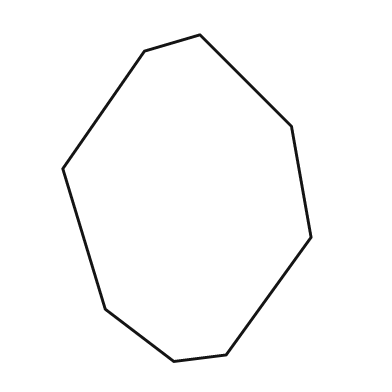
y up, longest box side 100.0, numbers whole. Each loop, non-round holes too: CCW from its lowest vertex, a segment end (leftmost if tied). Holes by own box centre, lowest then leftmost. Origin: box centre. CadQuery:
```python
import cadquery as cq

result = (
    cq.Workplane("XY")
    .moveTo(-4.0, -50.0)
    .lineTo(12.0, -48.0)
    .lineTo(38.0, -12.0)
    .lineTo(32.0, 22.0)
    .lineTo(4.0, 50.0)
    .lineTo(-13.0, 45.0)
    .lineTo(-38.0, 9.0)
    .lineTo(-25.0, -34.0)
    .close()
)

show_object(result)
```